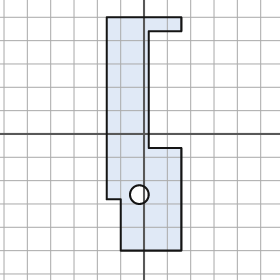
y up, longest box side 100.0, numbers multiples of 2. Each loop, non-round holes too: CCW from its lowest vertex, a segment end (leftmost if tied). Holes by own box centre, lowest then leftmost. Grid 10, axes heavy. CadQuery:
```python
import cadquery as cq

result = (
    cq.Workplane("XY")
    .moveTo(-10.0, -50.0)
    .lineTo(16.0, -50.0)
    .lineTo(16.0, -6.0)
    .lineTo(2.0, -6.0)
    .lineTo(2.0, 44.0)
    .lineTo(16.0, 44.0)
    .lineTo(16.0, 50.0)
    .lineTo(-16.0, 50.0)
    .lineTo(-16.0, -28.0)
    .lineTo(-10.0, -28.0)
    .close()
    .moveTo(-2.0, -26.0)
    .circle(4.0)
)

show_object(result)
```